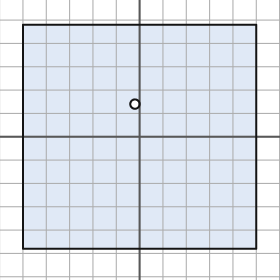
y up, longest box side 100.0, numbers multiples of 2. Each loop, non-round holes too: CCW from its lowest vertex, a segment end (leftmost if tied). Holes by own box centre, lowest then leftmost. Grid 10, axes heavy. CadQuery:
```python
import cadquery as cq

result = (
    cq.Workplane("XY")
    .moveTo(-50.0, -48.0)
    .lineTo(50.0, -48.0)
    .lineTo(50.0, 48.0)
    .lineTo(-50.0, 48.0)
    .close()
    .moveTo(-2.0, 14.0)
    .circle(2.0)
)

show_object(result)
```